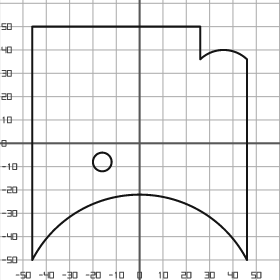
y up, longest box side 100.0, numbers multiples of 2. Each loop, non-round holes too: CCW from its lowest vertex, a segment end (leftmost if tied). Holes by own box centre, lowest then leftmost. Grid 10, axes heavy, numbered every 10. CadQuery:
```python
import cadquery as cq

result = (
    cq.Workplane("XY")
    .moveTo(-46.0, -50.0)
    .threePointArc((0.0, -22.0), (46.0, -50.0))
    .lineTo(46.0, 36.0)
    .threePointArc((36.0, 40.0), (26.0, 36.0))
    .lineTo(26.0, 50.0)
    .lineTo(-46.0, 50.0)
    .close()
    .moveTo(-16.0, -8.0)
    .circle(4.0)
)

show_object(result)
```